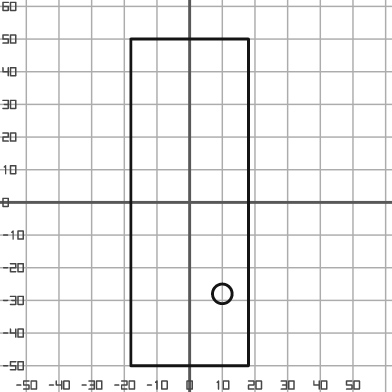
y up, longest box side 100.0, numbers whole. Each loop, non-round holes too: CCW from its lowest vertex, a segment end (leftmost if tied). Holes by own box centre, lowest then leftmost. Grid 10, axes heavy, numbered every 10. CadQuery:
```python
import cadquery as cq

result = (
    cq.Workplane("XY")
    .moveTo(-18.0, -50.0)
    .lineTo(18.0, -50.0)
    .lineTo(18.0, 50.0)
    .lineTo(-18.0, 50.0)
    .close()
    .moveTo(10.0, -28.0)
    .circle(3.0)
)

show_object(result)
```